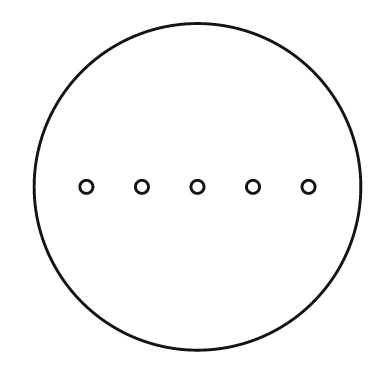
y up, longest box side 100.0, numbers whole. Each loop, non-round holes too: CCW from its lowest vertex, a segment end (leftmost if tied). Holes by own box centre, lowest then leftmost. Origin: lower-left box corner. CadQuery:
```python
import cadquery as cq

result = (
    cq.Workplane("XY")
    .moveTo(50.0, 50.0)
    .circle(50.0)
    .moveTo(16.0, 50.0)
    .circle(2.0)
    .moveTo(33.0, 50.0)
    .circle(2.0)
    .moveTo(50.0, 50.0)
    .circle(2.0)
    .moveTo(67.0, 50.0)
    .circle(2.0)
    .moveTo(84.0, 50.0)
    .circle(2.0)
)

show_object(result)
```